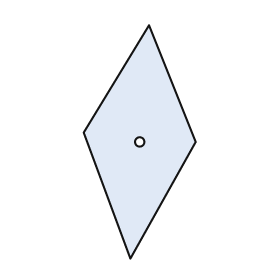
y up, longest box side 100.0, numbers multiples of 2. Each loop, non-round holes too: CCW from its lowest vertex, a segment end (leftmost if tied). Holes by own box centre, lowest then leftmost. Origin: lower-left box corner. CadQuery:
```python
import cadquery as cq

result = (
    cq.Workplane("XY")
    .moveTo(20.0, 0.0)
    .lineTo(48.0, 50.0)
    .lineTo(28.0, 100.0)
    .lineTo(0.0, 54.0)
    .close()
    .moveTo(24.0, 50.0)
    .circle(2.0)
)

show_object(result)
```